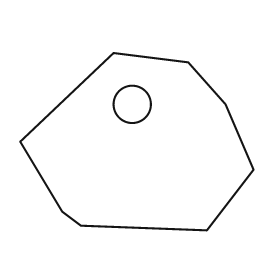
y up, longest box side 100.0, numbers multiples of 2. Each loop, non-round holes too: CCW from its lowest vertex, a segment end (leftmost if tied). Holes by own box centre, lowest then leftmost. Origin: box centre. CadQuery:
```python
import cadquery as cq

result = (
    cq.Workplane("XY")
    .moveTo(30.0, -38.0)
    .lineTo(50.0, -12.0)
    .lineTo(38.0, 16.0)
    .lineTo(22.0, 34.0)
    .lineTo(-10.0, 38.0)
    .lineTo(-50.0, 0.0)
    .lineTo(-32.0, -30.0)
    .lineTo(-24.0, -36.0)
    .close()
    .moveTo(-2.0, 16.0)
    .circle(8.0)
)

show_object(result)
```